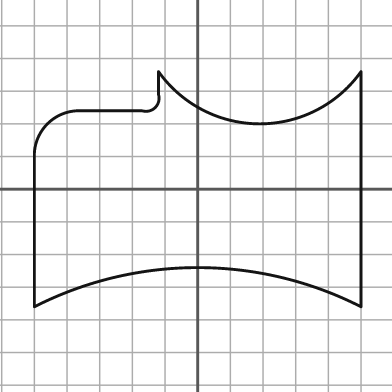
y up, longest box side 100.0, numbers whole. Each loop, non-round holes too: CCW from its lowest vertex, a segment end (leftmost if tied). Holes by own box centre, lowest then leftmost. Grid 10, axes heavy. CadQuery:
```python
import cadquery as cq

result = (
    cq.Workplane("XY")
    .moveTo(-50.0, -36.0)
    .threePointArc((0.0, -24.0), (50.0, -36.0))
    .lineTo(50.0, 36.0)
    .threePointArc((19.0, 20.0), (-12.0, 36.0))
    .lineTo(-12.0, 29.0)
    .threePointArc((-13.0, 25.0), (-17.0, 24.0))
    .lineTo(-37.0, 24.0)
    .threePointArc((-46.0, 20.0), (-50.0, 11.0))
    .close()
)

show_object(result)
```